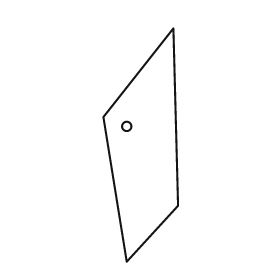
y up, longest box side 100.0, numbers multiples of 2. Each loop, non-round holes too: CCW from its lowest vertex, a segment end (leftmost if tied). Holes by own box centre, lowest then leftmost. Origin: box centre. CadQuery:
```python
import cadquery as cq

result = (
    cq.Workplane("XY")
    .moveTo(-6.0, -50.0)
    .lineTo(16.0, -26.0)
    .lineTo(14.0, 50.0)
    .lineTo(-16.0, 12.0)
    .close()
    .moveTo(-6.0, 8.0)
    .circle(2.0)
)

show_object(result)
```